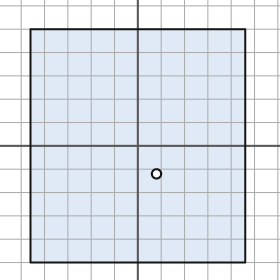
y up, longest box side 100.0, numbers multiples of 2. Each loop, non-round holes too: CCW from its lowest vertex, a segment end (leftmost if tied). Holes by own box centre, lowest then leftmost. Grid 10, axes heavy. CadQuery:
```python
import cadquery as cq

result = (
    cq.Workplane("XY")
    .moveTo(-46.0, -50.0)
    .lineTo(46.0, -50.0)
    .lineTo(46.0, 50.0)
    .lineTo(-46.0, 50.0)
    .close()
    .moveTo(8.0, -12.0)
    .circle(2.0)
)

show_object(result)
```